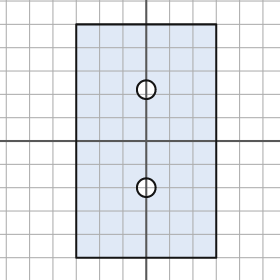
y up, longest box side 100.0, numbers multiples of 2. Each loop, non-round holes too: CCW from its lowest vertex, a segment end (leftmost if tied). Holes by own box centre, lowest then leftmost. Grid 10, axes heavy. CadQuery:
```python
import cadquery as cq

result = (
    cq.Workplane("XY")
    .moveTo(-30.0, -50.0)
    .lineTo(30.0, -50.0)
    .lineTo(30.0, 50.0)
    .lineTo(-30.0, 50.0)
    .close()
    .moveTo(0.0, -20.0)
    .circle(4.0)
    .moveTo(0.0, 22.0)
    .circle(4.0)
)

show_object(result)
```